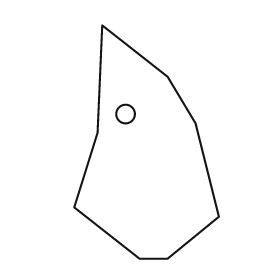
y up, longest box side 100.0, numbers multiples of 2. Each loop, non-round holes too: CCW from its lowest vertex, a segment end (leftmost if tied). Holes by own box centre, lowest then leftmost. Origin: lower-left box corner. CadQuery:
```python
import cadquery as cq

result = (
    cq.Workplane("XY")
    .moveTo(28.0, 0.0)
    .lineTo(40.0, 0.0)
    .lineTo(62.0, 18.0)
    .lineTo(52.0, 58.0)
    .lineTo(40.0, 78.0)
    .lineTo(12.0, 100.0)
    .lineTo(10.0, 54.0)
    .lineTo(0.0, 22.0)
    .close()
    .moveTo(22.0, 62.0)
    .circle(4.0)
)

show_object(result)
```